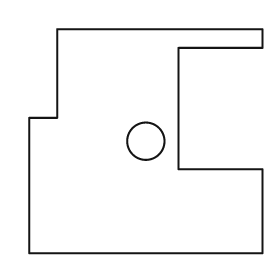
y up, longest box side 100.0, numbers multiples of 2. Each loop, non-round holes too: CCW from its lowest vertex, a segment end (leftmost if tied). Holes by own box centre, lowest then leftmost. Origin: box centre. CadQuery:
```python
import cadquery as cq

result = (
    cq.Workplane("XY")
    .moveTo(-50.0, -48.0)
    .lineTo(50.0, -48.0)
    .lineTo(50.0, -12.0)
    .lineTo(14.0, -12.0)
    .lineTo(14.0, 40.0)
    .lineTo(50.0, 40.0)
    .lineTo(50.0, 48.0)
    .lineTo(-38.0, 48.0)
    .lineTo(-38.0, 10.0)
    .lineTo(-50.0, 10.0)
    .close()
    .moveTo(0.0, 0.0)
    .circle(8.0)
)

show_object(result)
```